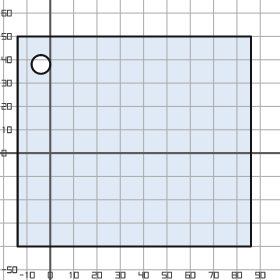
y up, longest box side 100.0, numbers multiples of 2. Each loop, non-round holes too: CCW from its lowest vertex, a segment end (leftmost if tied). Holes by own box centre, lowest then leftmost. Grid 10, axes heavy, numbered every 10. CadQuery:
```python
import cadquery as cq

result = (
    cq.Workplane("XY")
    .moveTo(-14.0, -40.0)
    .lineTo(86.0, -40.0)
    .lineTo(86.0, 50.0)
    .lineTo(-14.0, 50.0)
    .close()
    .moveTo(-4.0, 38.0)
    .circle(4.0)
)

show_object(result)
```